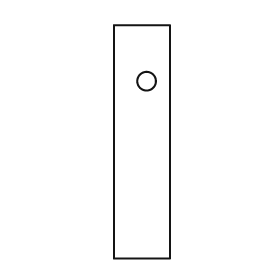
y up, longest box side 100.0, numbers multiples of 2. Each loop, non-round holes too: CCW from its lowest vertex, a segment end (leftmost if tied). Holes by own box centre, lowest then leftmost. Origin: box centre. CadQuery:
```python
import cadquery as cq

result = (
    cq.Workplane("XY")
    .moveTo(-12.0, -50.0)
    .lineTo(12.0, -50.0)
    .lineTo(12.0, 50.0)
    .lineTo(-12.0, 50.0)
    .close()
    .moveTo(2.0, 26.0)
    .circle(4.0)
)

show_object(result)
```